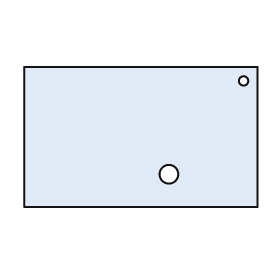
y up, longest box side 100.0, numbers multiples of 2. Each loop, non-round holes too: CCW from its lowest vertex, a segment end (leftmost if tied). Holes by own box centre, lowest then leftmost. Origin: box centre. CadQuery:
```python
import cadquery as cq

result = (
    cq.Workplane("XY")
    .moveTo(-50.0, -30.0)
    .lineTo(50.0, -30.0)
    .lineTo(50.0, 30.0)
    .lineTo(-50.0, 30.0)
    .close()
    .moveTo(12.0, -16.0)
    .circle(4.0)
    .moveTo(44.0, 24.0)
    .circle(2.0)
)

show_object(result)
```